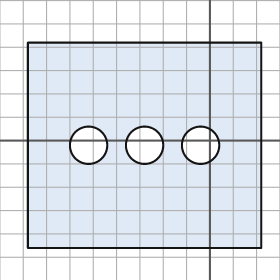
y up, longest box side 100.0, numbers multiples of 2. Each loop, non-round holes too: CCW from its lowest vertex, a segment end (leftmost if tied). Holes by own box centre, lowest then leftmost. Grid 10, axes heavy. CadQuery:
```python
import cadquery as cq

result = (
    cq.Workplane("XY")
    .moveTo(-78.0, -46.0)
    .lineTo(22.0, -46.0)
    .lineTo(22.0, 42.0)
    .lineTo(-78.0, 42.0)
    .close()
    .moveTo(-52.0, -2.0)
    .circle(8.0)
    .moveTo(-28.0, -2.0)
    .circle(8.0)
    .moveTo(-4.0, -2.0)
    .circle(8.0)
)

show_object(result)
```